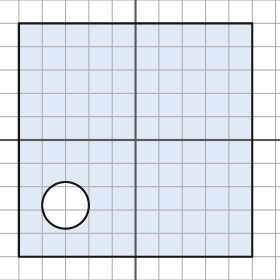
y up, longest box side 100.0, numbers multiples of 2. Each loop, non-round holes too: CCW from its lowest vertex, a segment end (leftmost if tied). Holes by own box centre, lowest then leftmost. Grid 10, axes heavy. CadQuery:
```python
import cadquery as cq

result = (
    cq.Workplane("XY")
    .moveTo(-50.0, -50.0)
    .lineTo(50.0, -50.0)
    .lineTo(50.0, 50.0)
    .lineTo(-50.0, 50.0)
    .close()
    .moveTo(-30.0, -28.0)
    .circle(10.0)
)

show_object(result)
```